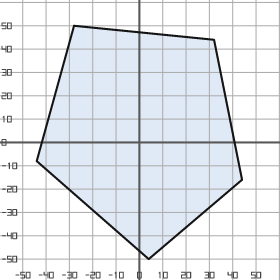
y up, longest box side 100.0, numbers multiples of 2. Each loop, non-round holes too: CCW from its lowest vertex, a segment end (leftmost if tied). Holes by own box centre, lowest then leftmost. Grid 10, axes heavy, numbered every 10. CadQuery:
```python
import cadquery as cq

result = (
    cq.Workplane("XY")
    .moveTo(4.0, -50.0)
    .lineTo(44.0, -16.0)
    .lineTo(32.0, 44.0)
    .lineTo(-28.0, 50.0)
    .lineTo(-44.0, -8.0)
    .close()
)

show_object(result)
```